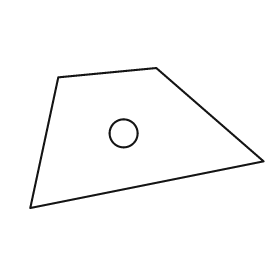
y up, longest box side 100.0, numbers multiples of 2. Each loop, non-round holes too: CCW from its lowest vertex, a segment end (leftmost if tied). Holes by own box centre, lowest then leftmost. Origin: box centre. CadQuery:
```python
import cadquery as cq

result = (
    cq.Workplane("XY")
    .moveTo(-50.0, -30.0)
    .lineTo(50.0, -10.0)
    .lineTo(4.0, 30.0)
    .lineTo(-38.0, 26.0)
    .close()
    .moveTo(-10.0, 2.0)
    .circle(6.0)
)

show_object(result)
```